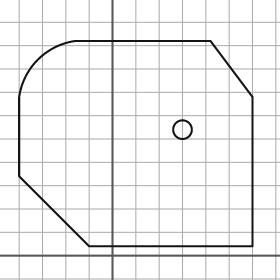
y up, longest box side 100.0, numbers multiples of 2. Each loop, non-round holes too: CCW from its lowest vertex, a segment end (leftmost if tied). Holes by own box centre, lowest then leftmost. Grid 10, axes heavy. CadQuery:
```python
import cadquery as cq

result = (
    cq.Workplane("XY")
    .moveTo(-10.0, 4.0)
    .lineTo(60.0, 4.0)
    .lineTo(60.0, 68.0)
    .lineTo(42.0, 92.0)
    .lineTo(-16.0, 92.0)
    .threePointArc((-32.0, 84.0), (-40.0, 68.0))
    .lineTo(-40.0, 34.0)
    .close()
    .moveTo(30.0, 54.0)
    .circle(4.0)
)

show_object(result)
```